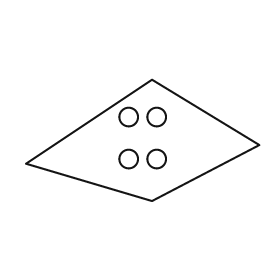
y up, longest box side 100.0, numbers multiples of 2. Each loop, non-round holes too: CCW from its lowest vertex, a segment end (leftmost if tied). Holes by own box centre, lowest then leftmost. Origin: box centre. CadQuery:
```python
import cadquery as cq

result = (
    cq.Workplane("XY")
    .moveTo(4.0, -26.0)
    .lineTo(50.0, -2.0)
    .lineTo(4.0, 26.0)
    .lineTo(-50.0, -10.0)
    .close()
    .moveTo(-6.0, -8.0)
    .circle(4.0)
    .moveTo(6.0, -8.0)
    .circle(4.0)
    .moveTo(-6.0, 10.0)
    .circle(4.0)
    .moveTo(6.0, 10.0)
    .circle(4.0)
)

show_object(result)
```